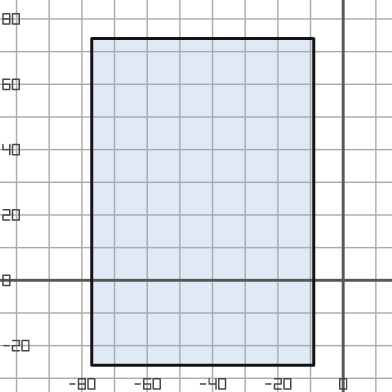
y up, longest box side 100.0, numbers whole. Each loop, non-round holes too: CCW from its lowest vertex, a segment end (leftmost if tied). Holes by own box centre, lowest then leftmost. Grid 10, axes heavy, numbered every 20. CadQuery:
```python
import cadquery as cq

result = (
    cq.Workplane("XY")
    .moveTo(-77.0, -26.0)
    .lineTo(-9.0, -26.0)
    .lineTo(-9.0, 74.0)
    .lineTo(-77.0, 74.0)
    .close()
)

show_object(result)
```